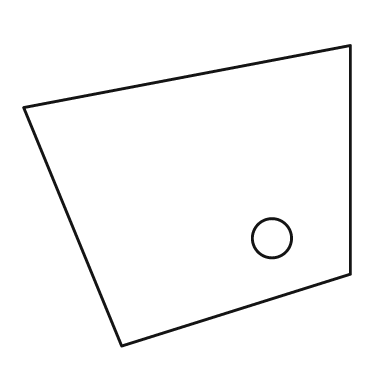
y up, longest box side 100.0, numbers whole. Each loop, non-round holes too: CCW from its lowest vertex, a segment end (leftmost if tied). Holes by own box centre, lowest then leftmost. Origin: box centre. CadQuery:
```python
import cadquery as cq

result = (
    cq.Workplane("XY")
    .moveTo(-20.0, -46.0)
    .lineTo(50.0, -24.0)
    .lineTo(50.0, 46.0)
    .lineTo(-50.0, 27.0)
    .close()
    .moveTo(26.0, -13.0)
    .circle(6.0)
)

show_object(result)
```